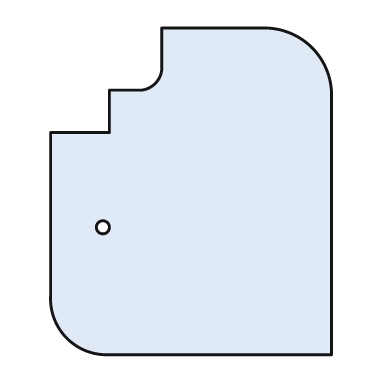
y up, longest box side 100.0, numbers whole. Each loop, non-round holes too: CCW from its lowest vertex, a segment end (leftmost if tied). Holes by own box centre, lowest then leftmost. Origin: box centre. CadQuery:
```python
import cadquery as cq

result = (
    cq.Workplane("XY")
    .moveTo(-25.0, -50.0)
    .lineTo(43.0, -50.0)
    .lineTo(43.0, 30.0)
    .threePointArc((37.0, 44.0), (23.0, 50.0))
    .lineTo(-9.0, 50.0)
    .lineTo(-9.0, 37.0)
    .threePointArc((-11.0, 33.0), (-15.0, 31.0))
    .lineTo(-25.0, 31.0)
    .lineTo(-25.0, 18.0)
    .lineTo(-43.0, 18.0)
    .lineTo(-43.0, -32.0)
    .threePointArc((-38.0, -45.0), (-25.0, -50.0))
    .close()
    .moveTo(-27.0, -11.0)
    .circle(2.0)
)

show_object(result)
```